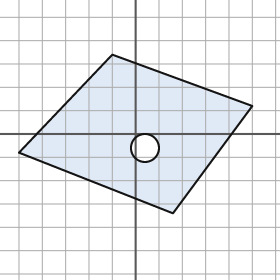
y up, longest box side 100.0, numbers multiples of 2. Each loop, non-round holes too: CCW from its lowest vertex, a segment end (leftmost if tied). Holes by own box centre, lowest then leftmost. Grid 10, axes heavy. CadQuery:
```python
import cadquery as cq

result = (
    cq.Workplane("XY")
    .moveTo(16.0, -34.0)
    .lineTo(50.0, 12.0)
    .lineTo(-10.0, 34.0)
    .lineTo(-50.0, -8.0)
    .close()
    .moveTo(4.0, -6.0)
    .circle(6.0)
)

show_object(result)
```